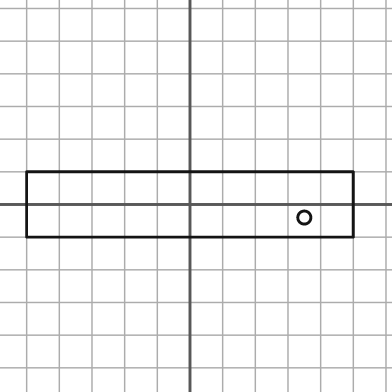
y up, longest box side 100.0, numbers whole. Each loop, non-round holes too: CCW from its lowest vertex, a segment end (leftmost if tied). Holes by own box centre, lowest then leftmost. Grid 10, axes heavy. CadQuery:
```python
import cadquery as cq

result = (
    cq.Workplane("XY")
    .moveTo(-50.0, -10.0)
    .lineTo(50.0, -10.0)
    .lineTo(50.0, 10.0)
    .lineTo(-50.0, 10.0)
    .close()
    .moveTo(35.0, -4.0)
    .circle(2.0)
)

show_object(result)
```